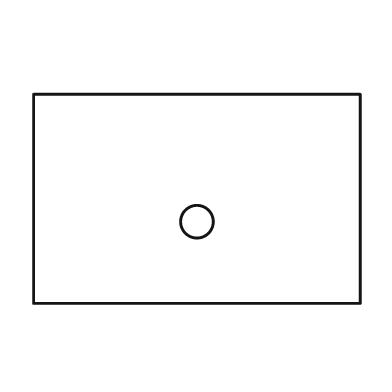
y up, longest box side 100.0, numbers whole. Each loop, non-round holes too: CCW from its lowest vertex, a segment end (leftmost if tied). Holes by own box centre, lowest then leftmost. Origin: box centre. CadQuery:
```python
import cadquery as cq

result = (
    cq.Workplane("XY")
    .moveTo(-50.0, -32.0)
    .lineTo(50.0, -32.0)
    .lineTo(50.0, 32.0)
    .lineTo(-50.0, 32.0)
    .close()
    .moveTo(0.0, -7.0)
    .circle(5.0)
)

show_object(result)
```